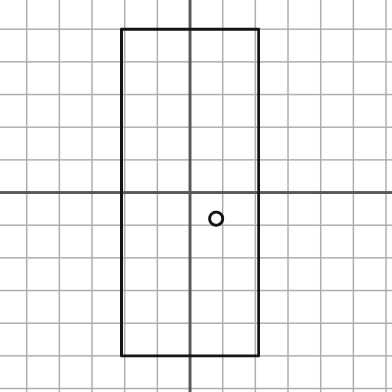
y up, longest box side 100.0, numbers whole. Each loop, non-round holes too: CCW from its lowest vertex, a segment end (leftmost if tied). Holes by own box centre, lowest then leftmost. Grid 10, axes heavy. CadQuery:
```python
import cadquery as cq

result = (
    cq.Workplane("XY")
    .moveTo(-21.0, -50.0)
    .lineTo(21.0, -50.0)
    .lineTo(21.0, 50.0)
    .lineTo(-21.0, 50.0)
    .close()
    .moveTo(8.0, -8.0)
    .circle(2.0)
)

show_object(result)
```